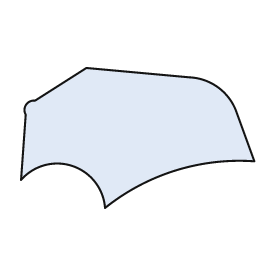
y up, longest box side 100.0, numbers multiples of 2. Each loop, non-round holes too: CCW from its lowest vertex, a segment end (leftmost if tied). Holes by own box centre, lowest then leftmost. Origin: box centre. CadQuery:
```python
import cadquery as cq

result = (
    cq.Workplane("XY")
    .moveTo(-14.0, -30.0)
    .threePointArc((16.0, -14.0), (50.0, -10.0))
    .lineTo(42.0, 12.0)
    .threePointArc((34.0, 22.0), (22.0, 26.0))
    .lineTo(-22.0, 30.0)
    .lineTo(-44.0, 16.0)
    .threePointArc((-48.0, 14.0), (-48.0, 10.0))
    .lineTo(-50.0, -18.0)
    .threePointArc((-28.0, -12.0), (-14.0, -30.0))
    .close()
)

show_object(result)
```